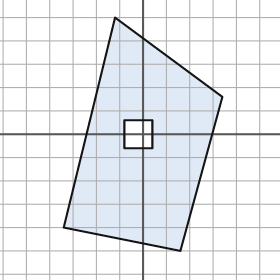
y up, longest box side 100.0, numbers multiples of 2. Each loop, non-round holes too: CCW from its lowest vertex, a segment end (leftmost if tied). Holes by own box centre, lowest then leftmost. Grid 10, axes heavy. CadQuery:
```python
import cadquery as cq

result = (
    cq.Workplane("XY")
    .moveTo(16.0, -50.0)
    .lineTo(34.0, 16.0)
    .lineTo(-12.0, 50.0)
    .lineTo(-34.0, -40.0)
    .close()
    .moveTo(-8.0, -6.0)
    .lineTo(4.0, -6.0)
    .lineTo(4.0, 6.0)
    .lineTo(-8.0, 6.0)
    .close()
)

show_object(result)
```